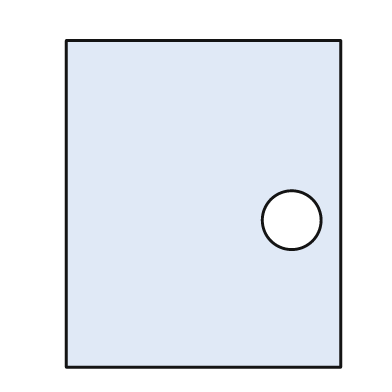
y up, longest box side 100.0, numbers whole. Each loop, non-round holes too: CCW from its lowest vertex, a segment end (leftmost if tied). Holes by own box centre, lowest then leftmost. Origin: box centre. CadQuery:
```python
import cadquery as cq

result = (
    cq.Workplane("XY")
    .moveTo(-42.0, -50.0)
    .lineTo(42.0, -50.0)
    .lineTo(42.0, 50.0)
    .lineTo(-42.0, 50.0)
    .close()
    .moveTo(27.0, -5.0)
    .circle(9.0)
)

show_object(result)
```